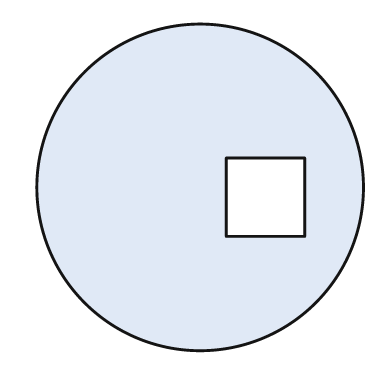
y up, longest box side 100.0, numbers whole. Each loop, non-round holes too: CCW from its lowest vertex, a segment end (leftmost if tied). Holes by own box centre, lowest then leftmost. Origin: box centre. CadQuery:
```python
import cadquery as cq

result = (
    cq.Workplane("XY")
    .moveTo(0.0, 0.0)
    .circle(50.0)
    .moveTo(8.0, -15.0)
    .lineTo(32.0, -15.0)
    .lineTo(32.0, 9.0)
    .lineTo(8.0, 9.0)
    .close()
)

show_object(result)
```